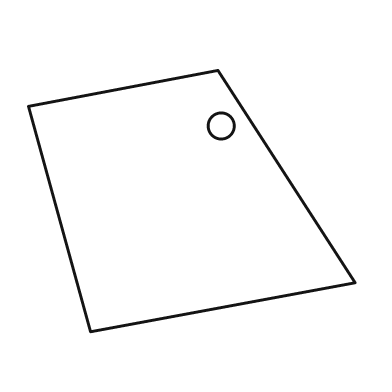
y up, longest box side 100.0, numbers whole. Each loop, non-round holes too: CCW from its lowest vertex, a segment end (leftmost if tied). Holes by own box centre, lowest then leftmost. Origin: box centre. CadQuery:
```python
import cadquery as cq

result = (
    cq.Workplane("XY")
    .moveTo(-31.0, -40.0)
    .lineTo(50.0, -25.0)
    .lineTo(8.0, 40.0)
    .lineTo(-50.0, 29.0)
    .close()
    .moveTo(9.0, 23.0)
    .circle(4.0)
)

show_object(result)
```